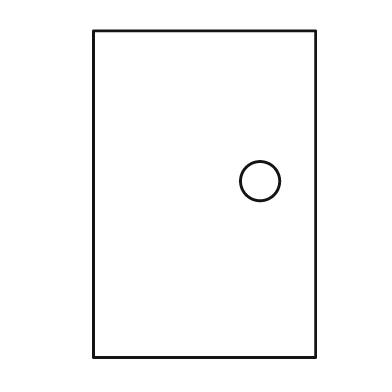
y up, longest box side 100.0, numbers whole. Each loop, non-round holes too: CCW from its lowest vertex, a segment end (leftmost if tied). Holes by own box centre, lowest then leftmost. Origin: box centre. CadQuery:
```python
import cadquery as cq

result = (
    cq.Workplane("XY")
    .moveTo(-34.0, -50.0)
    .lineTo(34.0, -50.0)
    .lineTo(34.0, 50.0)
    .lineTo(-34.0, 50.0)
    .close()
    .moveTo(17.0, 4.0)
    .circle(6.0)
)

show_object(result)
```